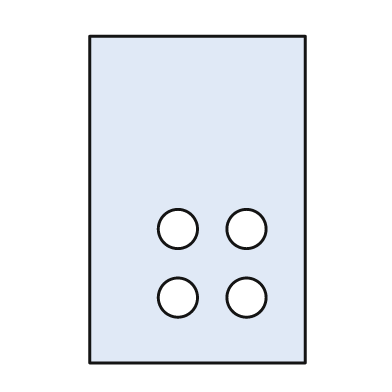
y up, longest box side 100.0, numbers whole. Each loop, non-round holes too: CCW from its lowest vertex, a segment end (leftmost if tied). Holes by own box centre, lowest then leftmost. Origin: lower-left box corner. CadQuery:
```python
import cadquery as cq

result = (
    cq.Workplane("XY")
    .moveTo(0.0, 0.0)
    .lineTo(66.0, 0.0)
    .lineTo(66.0, 100.0)
    .lineTo(0.0, 100.0)
    .close()
    .moveTo(27.0, 20.0)
    .circle(6.0)
    .moveTo(48.0, 20.0)
    .circle(6.0)
    .moveTo(27.0, 41.0)
    .circle(6.0)
    .moveTo(48.0, 41.0)
    .circle(6.0)
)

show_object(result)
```